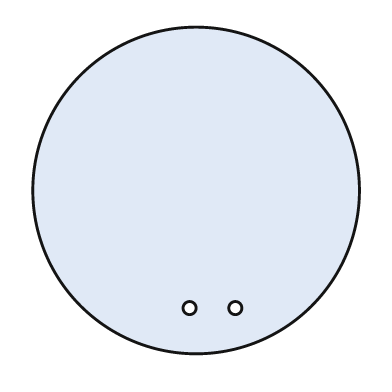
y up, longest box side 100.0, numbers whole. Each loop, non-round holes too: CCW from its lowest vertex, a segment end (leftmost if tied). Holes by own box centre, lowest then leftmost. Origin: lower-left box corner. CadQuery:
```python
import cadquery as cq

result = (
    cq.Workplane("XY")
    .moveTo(50.0, 50.0)
    .circle(50.0)
    .moveTo(48.0, 14.0)
    .circle(2.0)
    .moveTo(62.0, 14.0)
    .circle(2.0)
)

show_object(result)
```